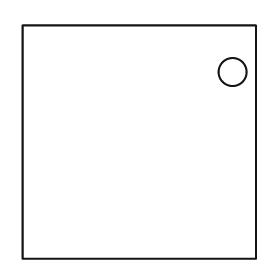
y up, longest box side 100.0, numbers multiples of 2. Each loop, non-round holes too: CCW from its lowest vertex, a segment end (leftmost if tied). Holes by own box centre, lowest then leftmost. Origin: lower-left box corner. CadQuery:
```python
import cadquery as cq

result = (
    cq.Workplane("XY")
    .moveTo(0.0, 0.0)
    .lineTo(100.0, 0.0)
    .lineTo(100.0, 100.0)
    .lineTo(0.0, 100.0)
    .close()
    .moveTo(90.0, 80.0)
    .circle(6.0)
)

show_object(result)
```